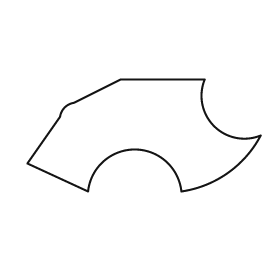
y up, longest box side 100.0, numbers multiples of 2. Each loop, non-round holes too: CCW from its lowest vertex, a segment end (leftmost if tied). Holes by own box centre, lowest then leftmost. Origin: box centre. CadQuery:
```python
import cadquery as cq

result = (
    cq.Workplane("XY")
    .moveTo(-24.0, -24.0)
    .threePointArc((-4.0, -6.0), (16.0, -24.0))
    .threePointArc((36.0, -16.0), (50.0, 0.0))
    .threePointArc((30.0, 4.0), (26.0, 24.0))
    .lineTo(-10.0, 24.0)
    .lineTo(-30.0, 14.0)
    .threePointArc((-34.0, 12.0), (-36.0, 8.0))
    .lineTo(-50.0, -12.0)
    .close()
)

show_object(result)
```